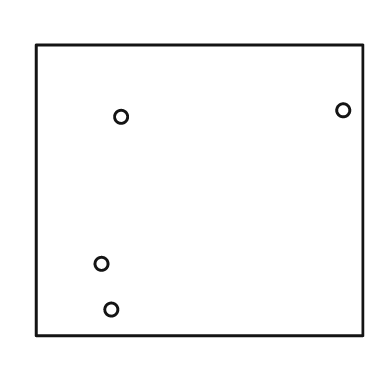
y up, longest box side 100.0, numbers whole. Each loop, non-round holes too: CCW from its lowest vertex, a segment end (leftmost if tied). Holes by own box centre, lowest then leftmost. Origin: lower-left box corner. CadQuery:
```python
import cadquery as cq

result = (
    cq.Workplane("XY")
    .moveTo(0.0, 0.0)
    .lineTo(100.0, 0.0)
    .lineTo(100.0, 89.0)
    .lineTo(0.0, 89.0)
    .close()
    .moveTo(23.0, 8.0)
    .circle(2.0)
    .moveTo(20.0, 22.0)
    .circle(2.0)
    .moveTo(26.0, 67.0)
    .circle(2.0)
    .moveTo(94.0, 69.0)
    .circle(2.0)
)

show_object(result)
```